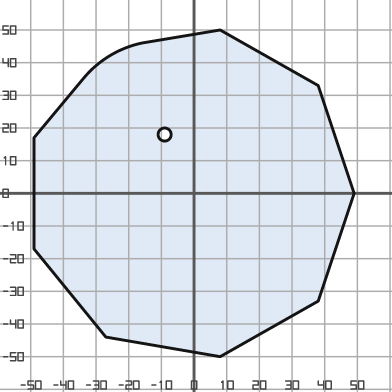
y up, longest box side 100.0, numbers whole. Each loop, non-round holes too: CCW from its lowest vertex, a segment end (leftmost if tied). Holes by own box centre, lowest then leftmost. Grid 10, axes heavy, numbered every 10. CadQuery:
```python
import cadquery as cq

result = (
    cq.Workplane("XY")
    .moveTo(8.0, -50.0)
    .lineTo(38.0, -33.0)
    .lineTo(49.0, 0.0)
    .lineTo(38.0, 33.0)
    .lineTo(8.0, 50.0)
    .lineTo(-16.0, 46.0)
    .threePointArc((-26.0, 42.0), (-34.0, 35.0))
    .lineTo(-49.0, 17.0)
    .lineTo(-49.0, -17.0)
    .lineTo(-27.0, -44.0)
    .close()
    .moveTo(-9.0, 18.0)
    .circle(2.0)
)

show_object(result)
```